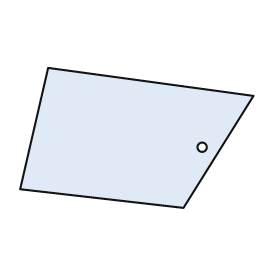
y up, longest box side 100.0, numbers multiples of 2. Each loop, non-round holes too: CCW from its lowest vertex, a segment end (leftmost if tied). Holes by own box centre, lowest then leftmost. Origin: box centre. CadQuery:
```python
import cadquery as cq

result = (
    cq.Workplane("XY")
    .moveTo(20.0, -30.0)
    .lineTo(50.0, 18.0)
    .lineTo(-38.0, 30.0)
    .lineTo(-50.0, -22.0)
    .close()
    .moveTo(28.0, -4.0)
    .circle(2.0)
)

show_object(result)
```